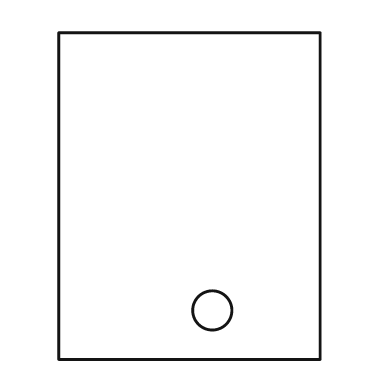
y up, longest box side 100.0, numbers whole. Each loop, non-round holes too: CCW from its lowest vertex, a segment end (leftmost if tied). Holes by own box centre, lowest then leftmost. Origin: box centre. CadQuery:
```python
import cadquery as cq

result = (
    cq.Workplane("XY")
    .moveTo(-40.0, -50.0)
    .lineTo(40.0, -50.0)
    .lineTo(40.0, 50.0)
    .lineTo(-40.0, 50.0)
    .close()
    .moveTo(7.0, -35.0)
    .circle(6.0)
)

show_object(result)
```